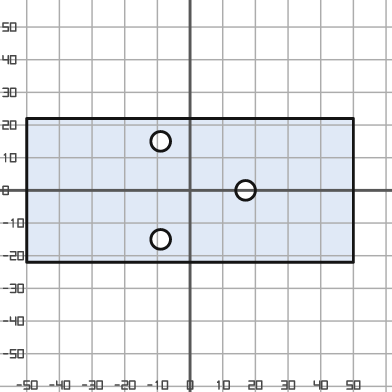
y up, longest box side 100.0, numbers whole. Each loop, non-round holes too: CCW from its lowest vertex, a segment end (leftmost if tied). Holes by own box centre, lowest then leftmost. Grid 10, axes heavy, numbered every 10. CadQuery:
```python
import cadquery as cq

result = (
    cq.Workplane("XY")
    .moveTo(-50.0, -22.0)
    .lineTo(50.0, -22.0)
    .lineTo(50.0, 22.0)
    .lineTo(-50.0, 22.0)
    .close()
    .moveTo(-9.0, -15.0)
    .circle(3.0)
    .moveTo(17.0, 0.0)
    .circle(3.0)
    .moveTo(-9.0, 15.0)
    .circle(3.0)
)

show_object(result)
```